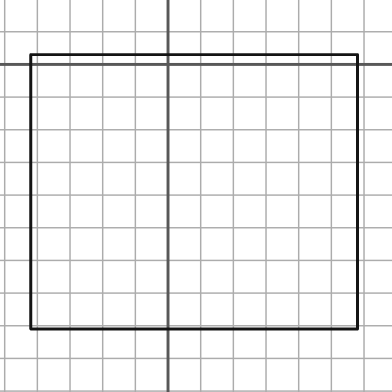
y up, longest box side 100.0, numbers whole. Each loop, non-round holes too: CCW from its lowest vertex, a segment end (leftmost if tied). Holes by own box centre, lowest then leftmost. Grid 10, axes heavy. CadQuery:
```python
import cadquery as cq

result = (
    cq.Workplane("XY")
    .moveTo(-42.0, -81.0)
    .lineTo(58.0, -81.0)
    .lineTo(58.0, 3.0)
    .lineTo(-42.0, 3.0)
    .close()
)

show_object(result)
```